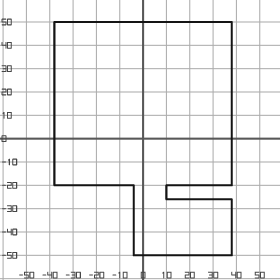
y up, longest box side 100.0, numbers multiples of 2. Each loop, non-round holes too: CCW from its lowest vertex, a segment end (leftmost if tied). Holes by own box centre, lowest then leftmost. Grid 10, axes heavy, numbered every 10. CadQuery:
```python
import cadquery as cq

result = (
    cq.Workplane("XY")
    .moveTo(-4.0, -50.0)
    .lineTo(38.0, -50.0)
    .lineTo(38.0, -26.0)
    .lineTo(10.0, -26.0)
    .lineTo(10.0, -20.0)
    .lineTo(38.0, -20.0)
    .lineTo(38.0, 50.0)
    .lineTo(-38.0, 50.0)
    .lineTo(-38.0, -20.0)
    .lineTo(-4.0, -20.0)
    .close()
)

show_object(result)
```